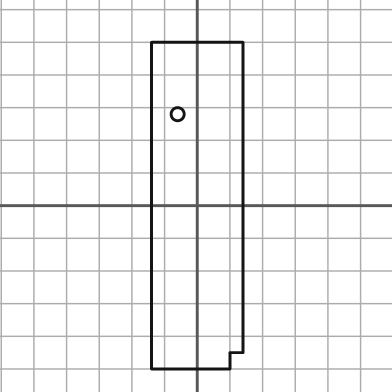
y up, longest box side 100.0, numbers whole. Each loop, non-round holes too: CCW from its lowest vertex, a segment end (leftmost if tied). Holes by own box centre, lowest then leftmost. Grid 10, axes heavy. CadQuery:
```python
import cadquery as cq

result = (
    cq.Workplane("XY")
    .moveTo(-14.0, -50.0)
    .lineTo(10.0, -50.0)
    .lineTo(10.0, -45.0)
    .lineTo(14.0, -45.0)
    .lineTo(14.0, 50.0)
    .lineTo(-14.0, 50.0)
    .close()
    .moveTo(-6.0, 28.0)
    .circle(2.0)
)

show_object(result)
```